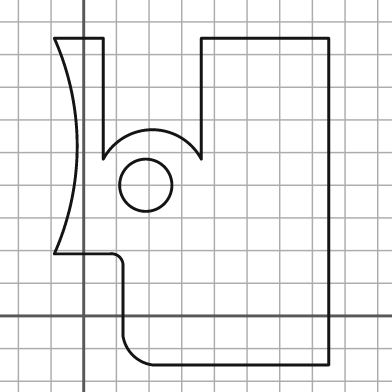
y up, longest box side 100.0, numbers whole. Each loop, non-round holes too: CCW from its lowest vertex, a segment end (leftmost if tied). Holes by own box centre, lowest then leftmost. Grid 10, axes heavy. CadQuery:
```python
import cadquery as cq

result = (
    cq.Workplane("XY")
    .moveTo(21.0, -15.0)
    .lineTo(75.0, -15.0)
    .lineTo(75.0, 85.0)
    .lineTo(36.0, 85.0)
    .lineTo(36.0, 48.0)
    .threePointArc((21.0, 57.0), (6.0, 48.0))
    .lineTo(6.0, 85.0)
    .lineTo(-9.0, 85.0)
    .threePointArc((-2.0, 52.0), (-9.0, 19.0))
    .lineTo(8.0, 19.0)
    .threePointArc((11.0, 18.0), (12.0, 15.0))
    .lineTo(12.0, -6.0)
    .threePointArc((15.0, -12.0), (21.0, -15.0))
    .close()
    .moveTo(19.0, 40.0)
    .circle(8.0)
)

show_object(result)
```